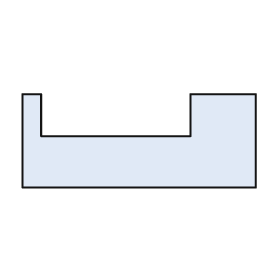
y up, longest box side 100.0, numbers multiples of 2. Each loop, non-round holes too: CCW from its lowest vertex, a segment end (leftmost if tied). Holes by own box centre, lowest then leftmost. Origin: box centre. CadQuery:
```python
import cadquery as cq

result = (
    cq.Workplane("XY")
    .moveTo(-50.0, -20.0)
    .lineTo(50.0, -20.0)
    .lineTo(50.0, 20.0)
    .lineTo(22.0, 20.0)
    .lineTo(22.0, 2.0)
    .lineTo(-42.0, 2.0)
    .lineTo(-42.0, 20.0)
    .lineTo(-50.0, 20.0)
    .close()
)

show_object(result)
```